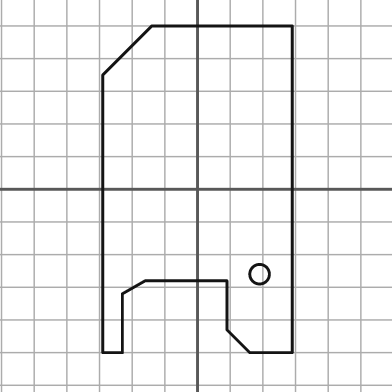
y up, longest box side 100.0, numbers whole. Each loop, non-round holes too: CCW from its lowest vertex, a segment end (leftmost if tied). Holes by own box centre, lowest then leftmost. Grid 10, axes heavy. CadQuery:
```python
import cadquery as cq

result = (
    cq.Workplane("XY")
    .moveTo(-29.0, -50.0)
    .lineTo(-23.0, -50.0)
    .lineTo(-23.0, -32.0)
    .lineTo(-16.0, -28.0)
    .lineTo(9.0, -28.0)
    .lineTo(9.0, -43.0)
    .lineTo(16.0, -50.0)
    .lineTo(29.0, -50.0)
    .lineTo(29.0, 50.0)
    .lineTo(-14.0, 50.0)
    .lineTo(-29.0, 35.0)
    .close()
    .moveTo(19.0, -26.0)
    .circle(3.0)
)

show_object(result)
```